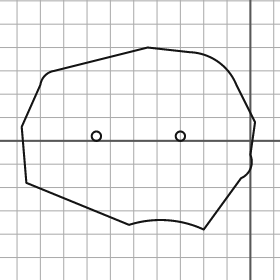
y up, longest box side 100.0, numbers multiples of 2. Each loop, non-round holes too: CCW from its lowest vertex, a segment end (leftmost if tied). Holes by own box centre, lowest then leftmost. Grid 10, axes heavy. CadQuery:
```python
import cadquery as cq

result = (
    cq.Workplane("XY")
    .moveTo(-20.0, -38.0)
    .lineTo(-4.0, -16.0)
    .threePointArc((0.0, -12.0), (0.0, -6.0))
    .lineTo(2.0, 8.0)
    .lineTo(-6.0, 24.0)
    .threePointArc((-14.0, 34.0), (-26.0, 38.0))
    .lineTo(-44.0, 40.0)
    .lineTo(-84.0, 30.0)
    .threePointArc((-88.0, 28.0), (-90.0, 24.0))
    .lineTo(-98.0, 6.0)
    .lineTo(-96.0, -18.0)
    .lineTo(-52.0, -36.0)
    .threePointArc((-36.0, -34.0), (-20.0, -38.0))
    .close()
    .moveTo(-66.0, 2.0)
    .circle(2.0)
    .moveTo(-30.0, 2.0)
    .circle(2.0)
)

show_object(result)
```